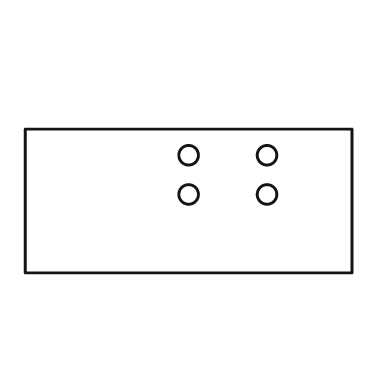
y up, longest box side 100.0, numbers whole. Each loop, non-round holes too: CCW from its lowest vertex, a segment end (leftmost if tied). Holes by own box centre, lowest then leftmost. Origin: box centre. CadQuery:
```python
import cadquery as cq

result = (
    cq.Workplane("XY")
    .moveTo(-50.0, -22.0)
    .lineTo(50.0, -22.0)
    .lineTo(50.0, 22.0)
    .lineTo(-50.0, 22.0)
    .close()
    .moveTo(0.0, 2.0)
    .circle(3.0)
    .moveTo(24.0, 2.0)
    .circle(3.0)
    .moveTo(0.0, 14.0)
    .circle(3.0)
    .moveTo(24.0, 14.0)
    .circle(3.0)
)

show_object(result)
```